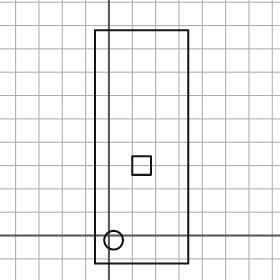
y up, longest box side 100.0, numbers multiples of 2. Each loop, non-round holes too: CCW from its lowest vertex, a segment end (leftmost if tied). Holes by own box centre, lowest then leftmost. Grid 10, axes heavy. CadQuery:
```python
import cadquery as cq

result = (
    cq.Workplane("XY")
    .moveTo(-6.0, -12.0)
    .lineTo(34.0, -12.0)
    .lineTo(34.0, 88.0)
    .lineTo(-6.0, 88.0)
    .close()
    .moveTo(2.0, -2.0)
    .circle(4.0)
    .moveTo(10.0, 26.0)
    .lineTo(18.0, 26.0)
    .lineTo(18.0, 34.0)
    .lineTo(10.0, 34.0)
    .close()
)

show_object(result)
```